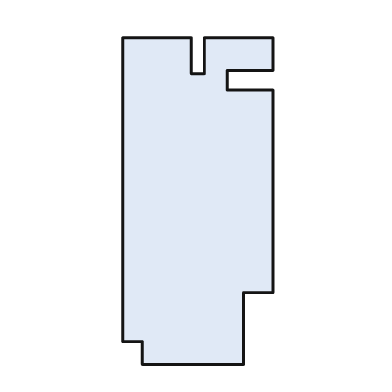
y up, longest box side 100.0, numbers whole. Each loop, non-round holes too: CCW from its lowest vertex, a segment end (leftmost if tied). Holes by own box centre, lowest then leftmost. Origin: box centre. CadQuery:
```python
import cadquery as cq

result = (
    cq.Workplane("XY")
    .moveTo(-17.0, -50.0)
    .lineTo(14.0, -50.0)
    .lineTo(14.0, -28.0)
    .lineTo(23.0, -28.0)
    .lineTo(23.0, 34.0)
    .lineTo(9.0, 34.0)
    .lineTo(9.0, 40.0)
    .lineTo(23.0, 40.0)
    .lineTo(23.0, 50.0)
    .lineTo(2.0, 50.0)
    .lineTo(2.0, 39.0)
    .lineTo(-2.0, 39.0)
    .lineTo(-2.0, 50.0)
    .lineTo(-23.0, 50.0)
    .lineTo(-23.0, -43.0)
    .lineTo(-17.0, -43.0)
    .close()
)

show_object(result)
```